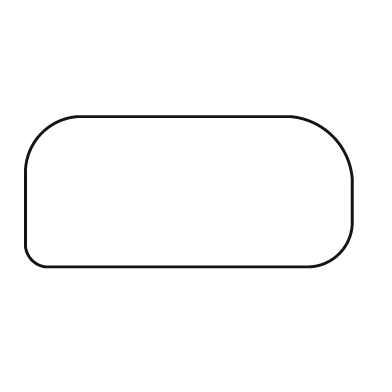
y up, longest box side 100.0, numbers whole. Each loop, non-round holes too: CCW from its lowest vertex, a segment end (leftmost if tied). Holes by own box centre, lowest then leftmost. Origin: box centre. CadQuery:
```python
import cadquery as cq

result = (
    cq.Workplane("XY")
    .moveTo(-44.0, -23.0)
    .lineTo(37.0, -23.0)
    .threePointArc((46.0, -19.0), (50.0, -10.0))
    .lineTo(50.0, 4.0)
    .threePointArc((44.0, 17.0), (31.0, 23.0))
    .lineTo(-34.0, 23.0)
    .threePointArc((-45.0, 18.0), (-50.0, 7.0))
    .lineTo(-50.0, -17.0)
    .threePointArc((-48.0, -21.0), (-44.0, -23.0))
    .close()
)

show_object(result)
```